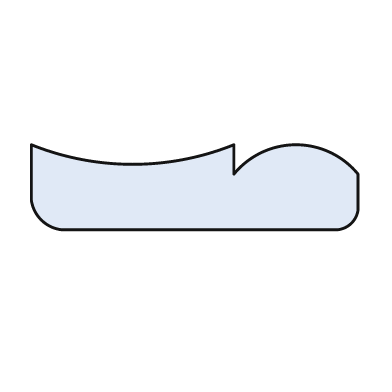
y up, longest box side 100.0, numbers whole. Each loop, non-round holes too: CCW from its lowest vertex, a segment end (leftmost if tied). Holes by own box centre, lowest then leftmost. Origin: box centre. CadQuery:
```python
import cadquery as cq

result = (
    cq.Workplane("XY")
    .moveTo(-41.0, -13.0)
    .lineTo(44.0, -13.0)
    .threePointArc((48.0, -11.0), (50.0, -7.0))
    .lineTo(50.0, 4.0)
    .threePointArc((31.0, 13.0), (12.0, 4.0))
    .lineTo(12.0, 13.0)
    .threePointArc((-19.0, 7.0), (-50.0, 13.0))
    .lineTo(-50.0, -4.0)
    .threePointArc((-47.0, -10.0), (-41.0, -13.0))
    .close()
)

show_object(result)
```